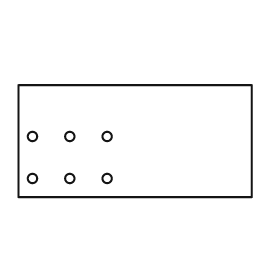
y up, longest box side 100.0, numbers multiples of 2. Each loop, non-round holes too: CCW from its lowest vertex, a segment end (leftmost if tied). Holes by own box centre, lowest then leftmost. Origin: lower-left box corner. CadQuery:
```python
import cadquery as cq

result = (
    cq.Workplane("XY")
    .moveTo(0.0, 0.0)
    .lineTo(100.0, 0.0)
    .lineTo(100.0, 48.0)
    .lineTo(0.0, 48.0)
    .close()
    .moveTo(6.0, 8.0)
    .circle(2.0)
    .moveTo(22.0, 8.0)
    .circle(2.0)
    .moveTo(38.0, 8.0)
    .circle(2.0)
    .moveTo(6.0, 26.0)
    .circle(2.0)
    .moveTo(22.0, 26.0)
    .circle(2.0)
    .moveTo(38.0, 26.0)
    .circle(2.0)
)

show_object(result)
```